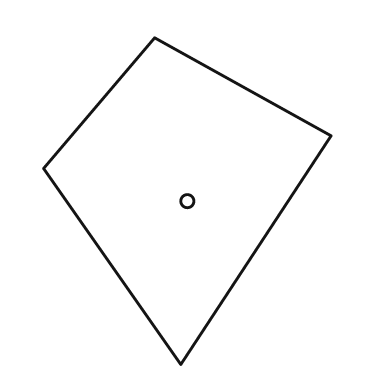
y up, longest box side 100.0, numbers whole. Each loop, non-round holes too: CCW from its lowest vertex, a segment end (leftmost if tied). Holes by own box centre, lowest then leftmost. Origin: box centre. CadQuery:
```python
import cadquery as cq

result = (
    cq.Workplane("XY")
    .moveTo(-2.0, -50.0)
    .lineTo(44.0, 20.0)
    .lineTo(-10.0, 50.0)
    .lineTo(-44.0, 10.0)
    .close()
    .moveTo(0.0, 0.0)
    .circle(2.0)
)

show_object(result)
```